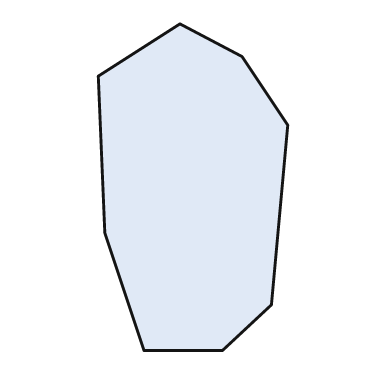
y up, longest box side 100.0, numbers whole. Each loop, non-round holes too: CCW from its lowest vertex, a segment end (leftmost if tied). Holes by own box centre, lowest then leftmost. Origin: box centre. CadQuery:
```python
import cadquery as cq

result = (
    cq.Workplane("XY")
    .moveTo(-15.0, -50.0)
    .lineTo(9.0, -50.0)
    .lineTo(24.0, -36.0)
    .lineTo(29.0, 19.0)
    .lineTo(15.0, 40.0)
    .lineTo(-4.0, 50.0)
    .lineTo(-29.0, 34.0)
    .lineTo(-27.0, -14.0)
    .close()
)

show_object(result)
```